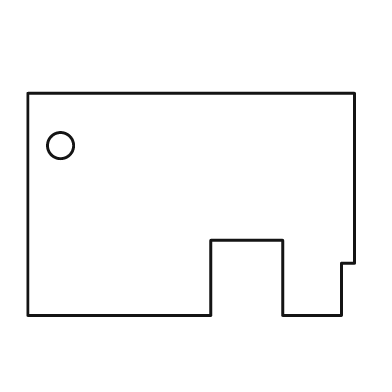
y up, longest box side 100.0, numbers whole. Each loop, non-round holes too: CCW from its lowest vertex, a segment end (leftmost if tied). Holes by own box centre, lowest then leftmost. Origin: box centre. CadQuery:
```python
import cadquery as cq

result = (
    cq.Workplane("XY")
    .moveTo(-50.0, -34.0)
    .lineTo(6.0, -34.0)
    .lineTo(6.0, -11.0)
    .lineTo(28.0, -11.0)
    .lineTo(28.0, -34.0)
    .lineTo(46.0, -34.0)
    .lineTo(46.0, -18.0)
    .lineTo(50.0, -18.0)
    .lineTo(50.0, 34.0)
    .lineTo(-50.0, 34.0)
    .close()
    .moveTo(-40.0, 18.0)
    .circle(4.0)
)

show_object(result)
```